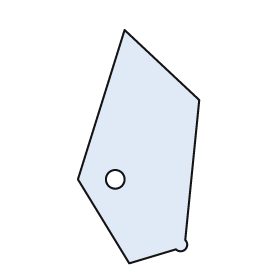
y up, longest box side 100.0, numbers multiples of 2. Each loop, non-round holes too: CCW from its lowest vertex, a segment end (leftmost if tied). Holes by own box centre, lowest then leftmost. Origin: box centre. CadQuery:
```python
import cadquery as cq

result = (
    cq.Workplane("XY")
    .moveTo(-4.0, -50.0)
    .lineTo(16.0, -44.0)
    .threePointArc((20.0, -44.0), (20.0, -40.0))
    .lineTo(26.0, 20.0)
    .lineTo(-6.0, 50.0)
    .lineTo(-26.0, -14.0)
    .close()
    .moveTo(-10.0, -14.0)
    .circle(4.0)
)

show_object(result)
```